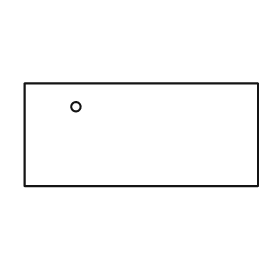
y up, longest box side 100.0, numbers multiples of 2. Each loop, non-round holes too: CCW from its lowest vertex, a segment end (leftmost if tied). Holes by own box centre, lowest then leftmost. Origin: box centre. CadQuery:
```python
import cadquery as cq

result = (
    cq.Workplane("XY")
    .moveTo(-50.0, -22.0)
    .lineTo(50.0, -22.0)
    .lineTo(50.0, 22.0)
    .lineTo(-50.0, 22.0)
    .close()
    .moveTo(-28.0, 12.0)
    .circle(2.0)
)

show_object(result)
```